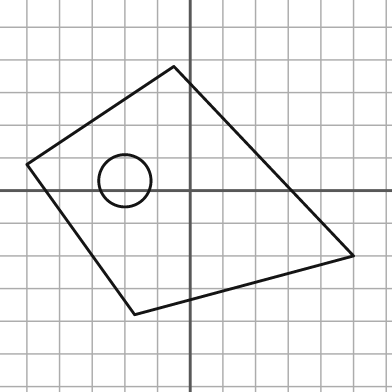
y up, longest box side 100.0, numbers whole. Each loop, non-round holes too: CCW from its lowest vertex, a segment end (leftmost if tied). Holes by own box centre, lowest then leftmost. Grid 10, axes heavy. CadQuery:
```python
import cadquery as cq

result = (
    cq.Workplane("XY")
    .moveTo(-17.0, -38.0)
    .lineTo(50.0, -20.0)
    .lineTo(-5.0, 38.0)
    .lineTo(-50.0, 8.0)
    .close()
    .moveTo(-20.0, 3.0)
    .circle(8.0)
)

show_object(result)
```